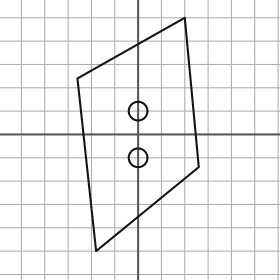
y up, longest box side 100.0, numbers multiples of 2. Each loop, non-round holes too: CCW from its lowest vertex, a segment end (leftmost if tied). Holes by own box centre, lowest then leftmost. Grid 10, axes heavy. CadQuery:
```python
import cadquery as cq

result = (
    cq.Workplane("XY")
    .moveTo(-18.0, -50.0)
    .lineTo(26.0, -14.0)
    .lineTo(20.0, 50.0)
    .lineTo(-26.0, 24.0)
    .close()
    .moveTo(0.0, -10.0)
    .circle(4.0)
    .moveTo(0.0, 10.0)
    .circle(4.0)
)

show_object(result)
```